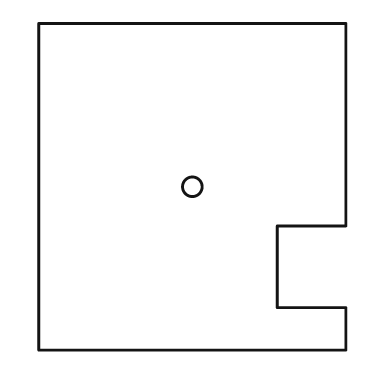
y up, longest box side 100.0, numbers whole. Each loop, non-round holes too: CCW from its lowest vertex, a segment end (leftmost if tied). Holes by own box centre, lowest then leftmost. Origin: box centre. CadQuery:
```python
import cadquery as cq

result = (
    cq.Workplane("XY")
    .moveTo(-47.0, -50.0)
    .lineTo(47.0, -50.0)
    .lineTo(47.0, -37.0)
    .lineTo(26.0, -37.0)
    .lineTo(26.0, -12.0)
    .lineTo(47.0, -12.0)
    .lineTo(47.0, 50.0)
    .lineTo(-47.0, 50.0)
    .close()
    .moveTo(0.0, 0.0)
    .circle(3.0)
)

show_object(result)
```